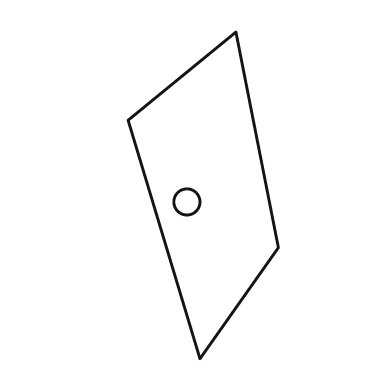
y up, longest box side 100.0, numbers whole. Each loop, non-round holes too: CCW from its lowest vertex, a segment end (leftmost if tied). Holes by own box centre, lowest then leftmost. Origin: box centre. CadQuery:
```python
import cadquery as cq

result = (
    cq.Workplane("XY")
    .moveTo(-1.0, -50.0)
    .lineTo(23.0, -16.0)
    .lineTo(10.0, 50.0)
    .lineTo(-23.0, 23.0)
    .close()
    .moveTo(-5.0, -2.0)
    .circle(4.0)
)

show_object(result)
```